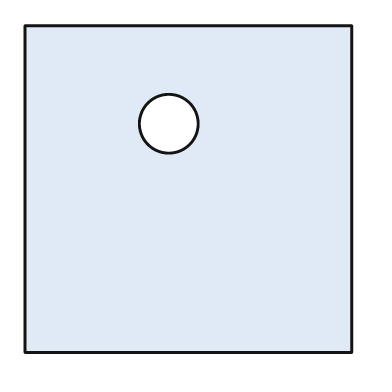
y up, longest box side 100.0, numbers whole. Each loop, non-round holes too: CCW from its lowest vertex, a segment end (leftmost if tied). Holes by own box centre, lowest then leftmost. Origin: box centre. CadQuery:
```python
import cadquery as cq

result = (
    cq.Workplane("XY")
    .moveTo(-50.0, -50.0)
    .lineTo(50.0, -50.0)
    .lineTo(50.0, 50.0)
    .lineTo(-50.0, 50.0)
    .close()
    .moveTo(-6.0, 20.0)
    .circle(9.0)
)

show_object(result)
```